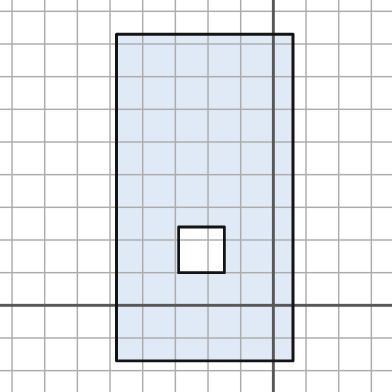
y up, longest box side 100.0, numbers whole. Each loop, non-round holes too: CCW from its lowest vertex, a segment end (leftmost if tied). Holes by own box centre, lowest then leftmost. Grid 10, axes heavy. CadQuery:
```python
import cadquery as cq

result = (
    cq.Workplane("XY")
    .moveTo(-48.0, -17.0)
    .lineTo(6.0, -17.0)
    .lineTo(6.0, 83.0)
    .lineTo(-48.0, 83.0)
    .close()
    .moveTo(-29.0, 10.0)
    .lineTo(-15.0, 10.0)
    .lineTo(-15.0, 24.0)
    .lineTo(-29.0, 24.0)
    .close()
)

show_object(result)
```